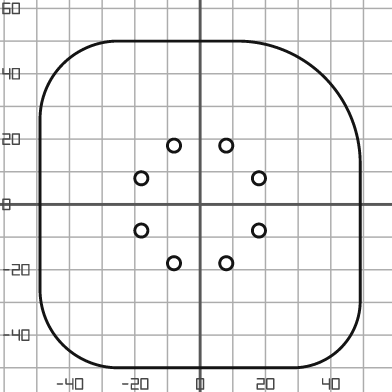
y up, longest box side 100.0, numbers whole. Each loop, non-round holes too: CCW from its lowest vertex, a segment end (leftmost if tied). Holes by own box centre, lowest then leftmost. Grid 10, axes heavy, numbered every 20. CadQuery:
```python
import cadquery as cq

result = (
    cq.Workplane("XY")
    .moveTo(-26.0, -50.0)
    .lineTo(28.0, -50.0)
    .threePointArc((43.0, -44.0), (49.0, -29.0))
    .lineTo(49.0, 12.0)
    .threePointArc((38.0, 39.0), (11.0, 50.0))
    .lineTo(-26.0, 50.0)
    .threePointArc((-42.0, 43.0), (-49.0, 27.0))
    .lineTo(-49.0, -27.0)
    .threePointArc((-42.0, -43.0), (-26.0, -50.0))
    .close()
    .moveTo(-8.0, -18.0)
    .circle(2.0)
    .moveTo(8.0, -18.0)
    .circle(2.0)
    .moveTo(-18.0, -8.0)
    .circle(2.0)
    .moveTo(18.0, -8.0)
    .circle(2.0)
    .moveTo(-18.0, 8.0)
    .circle(2.0)
    .moveTo(18.0, 8.0)
    .circle(2.0)
    .moveTo(-8.0, 18.0)
    .circle(2.0)
    .moveTo(8.0, 18.0)
    .circle(2.0)
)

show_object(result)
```